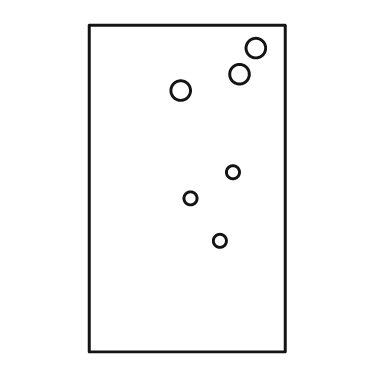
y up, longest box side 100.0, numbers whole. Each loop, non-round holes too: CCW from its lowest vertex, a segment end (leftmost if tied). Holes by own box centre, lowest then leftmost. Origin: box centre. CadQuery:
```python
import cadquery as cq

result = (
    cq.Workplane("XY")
    .moveTo(-30.0, -50.0)
    .lineTo(30.0, -50.0)
    .lineTo(30.0, 50.0)
    .lineTo(-30.0, 50.0)
    .close()
    .moveTo(10.0, -16.0)
    .circle(2.0)
    .moveTo(1.0, -3.0)
    .circle(2.0)
    .moveTo(14.0, 5.0)
    .circle(2.0)
    .moveTo(-2.0, 30.0)
    .circle(3.0)
    .moveTo(16.0, 35.0)
    .circle(3.0)
    .moveTo(21.0, 43.0)
    .circle(3.0)
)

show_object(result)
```